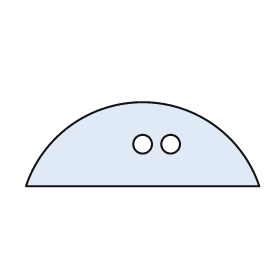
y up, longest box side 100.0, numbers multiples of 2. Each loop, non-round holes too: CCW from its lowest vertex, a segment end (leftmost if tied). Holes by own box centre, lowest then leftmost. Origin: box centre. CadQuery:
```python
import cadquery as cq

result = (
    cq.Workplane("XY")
    .moveTo(-50.0, -18.0)
    .lineTo(50.0, -18.0)
    .threePointArc((0.0, 18.0), (-50.0, -18.0))
    .close()
    .moveTo(0.0, 0.0)
    .circle(4.0)
    .moveTo(12.0, 0.0)
    .circle(4.0)
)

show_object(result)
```